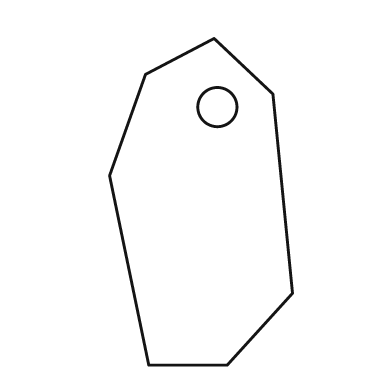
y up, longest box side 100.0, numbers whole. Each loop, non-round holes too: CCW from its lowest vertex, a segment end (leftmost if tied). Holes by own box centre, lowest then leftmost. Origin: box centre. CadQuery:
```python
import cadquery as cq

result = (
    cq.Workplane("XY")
    .moveTo(-16.0, -50.0)
    .lineTo(8.0, -50.0)
    .lineTo(28.0, -28.0)
    .lineTo(22.0, 33.0)
    .lineTo(4.0, 50.0)
    .lineTo(-17.0, 39.0)
    .lineTo(-28.0, 8.0)
    .close()
    .moveTo(5.0, 29.0)
    .circle(6.0)
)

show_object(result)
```